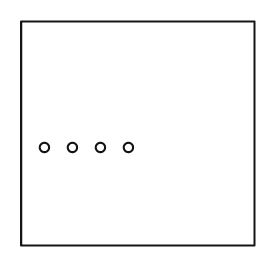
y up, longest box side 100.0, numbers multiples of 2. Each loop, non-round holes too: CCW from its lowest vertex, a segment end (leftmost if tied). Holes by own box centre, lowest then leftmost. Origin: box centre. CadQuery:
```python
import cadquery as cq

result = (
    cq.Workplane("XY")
    .moveTo(-50.0, -48.0)
    .lineTo(50.0, -48.0)
    .lineTo(50.0, 48.0)
    .lineTo(-50.0, 48.0)
    .close()
    .moveTo(-40.0, -6.0)
    .circle(2.0)
    .moveTo(-28.0, -6.0)
    .circle(2.0)
    .moveTo(-16.0, -6.0)
    .circle(2.0)
    .moveTo(-4.0, -6.0)
    .circle(2.0)
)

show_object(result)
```